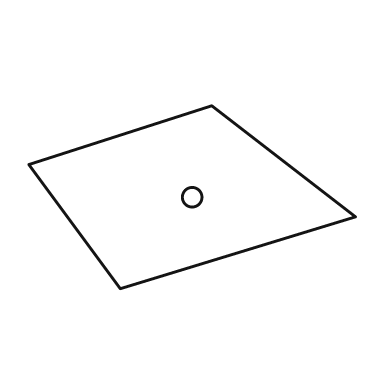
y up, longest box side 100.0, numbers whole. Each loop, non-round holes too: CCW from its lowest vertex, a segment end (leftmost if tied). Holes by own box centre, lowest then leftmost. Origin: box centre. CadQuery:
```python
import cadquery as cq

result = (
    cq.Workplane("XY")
    .moveTo(-22.0, -28.0)
    .lineTo(50.0, -6.0)
    .lineTo(6.0, 28.0)
    .lineTo(-50.0, 10.0)
    .close()
    .moveTo(0.0, 0.0)
    .circle(3.0)
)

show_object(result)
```